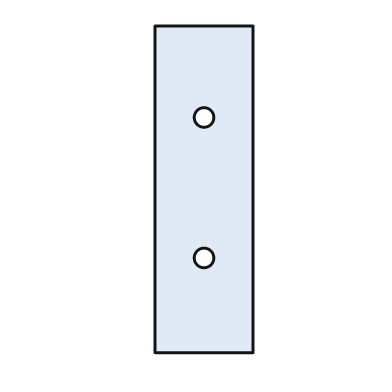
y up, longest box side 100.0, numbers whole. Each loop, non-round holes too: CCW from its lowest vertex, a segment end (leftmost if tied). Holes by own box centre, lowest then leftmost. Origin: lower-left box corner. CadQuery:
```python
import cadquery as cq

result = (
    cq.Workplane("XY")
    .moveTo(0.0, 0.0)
    .lineTo(30.0, 0.0)
    .lineTo(30.0, 100.0)
    .lineTo(0.0, 100.0)
    .close()
    .moveTo(15.0, 29.0)
    .circle(3.0)
    .moveTo(15.0, 72.0)
    .circle(3.0)
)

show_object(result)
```